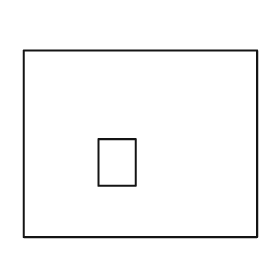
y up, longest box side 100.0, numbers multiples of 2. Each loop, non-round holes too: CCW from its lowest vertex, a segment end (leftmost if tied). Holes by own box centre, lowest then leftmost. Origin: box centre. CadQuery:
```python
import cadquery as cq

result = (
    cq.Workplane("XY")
    .moveTo(-50.0, -40.0)
    .lineTo(50.0, -40.0)
    .lineTo(50.0, 40.0)
    .lineTo(-50.0, 40.0)
    .close()
    .moveTo(-18.0, -18.0)
    .lineTo(-2.0, -18.0)
    .lineTo(-2.0, 2.0)
    .lineTo(-18.0, 2.0)
    .close()
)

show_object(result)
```